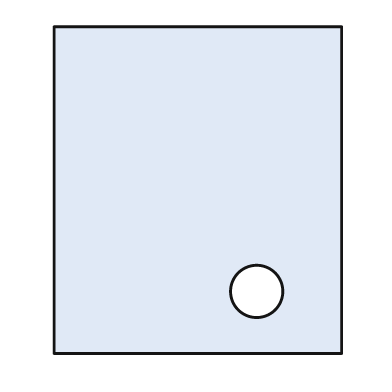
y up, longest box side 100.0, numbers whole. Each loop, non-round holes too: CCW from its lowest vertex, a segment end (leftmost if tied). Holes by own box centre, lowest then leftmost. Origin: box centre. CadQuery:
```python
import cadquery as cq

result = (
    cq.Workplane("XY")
    .moveTo(-44.0, -50.0)
    .lineTo(44.0, -50.0)
    .lineTo(44.0, 50.0)
    .lineTo(-44.0, 50.0)
    .close()
    .moveTo(18.0, -31.0)
    .circle(8.0)
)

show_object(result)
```